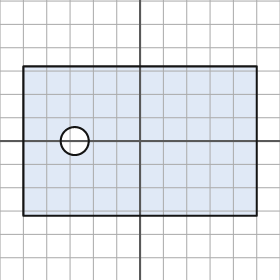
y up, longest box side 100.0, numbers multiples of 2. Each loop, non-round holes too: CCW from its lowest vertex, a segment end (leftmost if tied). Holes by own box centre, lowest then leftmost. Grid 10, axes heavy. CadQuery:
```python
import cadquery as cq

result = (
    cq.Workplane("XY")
    .moveTo(-50.0, -32.0)
    .lineTo(50.0, -32.0)
    .lineTo(50.0, 32.0)
    .lineTo(-50.0, 32.0)
    .close()
    .moveTo(-28.0, 0.0)
    .circle(6.0)
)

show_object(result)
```